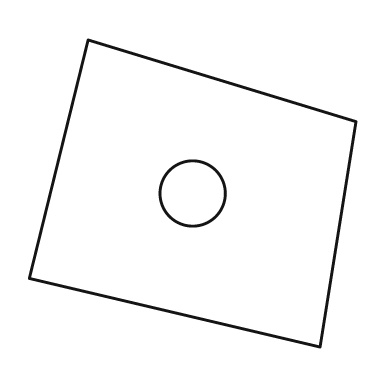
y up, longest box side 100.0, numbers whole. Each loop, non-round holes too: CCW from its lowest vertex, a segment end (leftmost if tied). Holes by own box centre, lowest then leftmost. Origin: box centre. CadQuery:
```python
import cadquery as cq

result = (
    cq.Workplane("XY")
    .moveTo(39.0, -47.0)
    .lineTo(50.0, 22.0)
    .lineTo(-32.0, 47.0)
    .lineTo(-50.0, -26.0)
    .close()
    .moveTo(0.0, 0.0)
    .circle(10.0)
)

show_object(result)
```